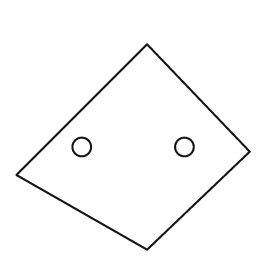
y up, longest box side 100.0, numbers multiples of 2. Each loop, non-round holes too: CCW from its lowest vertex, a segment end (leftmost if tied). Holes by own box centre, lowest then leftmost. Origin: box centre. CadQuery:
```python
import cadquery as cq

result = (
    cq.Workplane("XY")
    .moveTo(6.0, -44.0)
    .lineTo(50.0, -2.0)
    .lineTo(6.0, 44.0)
    .lineTo(-50.0, -12.0)
    .close()
    .moveTo(-22.0, 0.0)
    .circle(4.0)
    .moveTo(22.0, 0.0)
    .circle(4.0)
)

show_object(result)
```